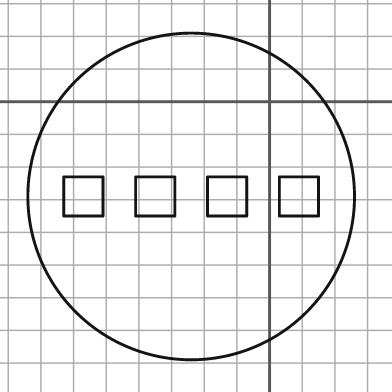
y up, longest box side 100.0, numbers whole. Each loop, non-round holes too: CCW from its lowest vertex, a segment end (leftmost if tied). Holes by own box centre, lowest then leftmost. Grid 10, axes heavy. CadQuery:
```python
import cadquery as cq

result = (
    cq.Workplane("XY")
    .moveTo(-24.0, -29.0)
    .circle(50.0)
    .moveTo(-63.0, -35.0)
    .lineTo(-51.0, -35.0)
    .lineTo(-51.0, -23.0)
    .lineTo(-63.0, -23.0)
    .close()
    .moveTo(-41.0, -35.0)
    .lineTo(-29.0, -35.0)
    .lineTo(-29.0, -23.0)
    .lineTo(-41.0, -23.0)
    .close()
    .moveTo(-19.0, -35.0)
    .lineTo(-7.0, -35.0)
    .lineTo(-7.0, -23.0)
    .lineTo(-19.0, -23.0)
    .close()
    .moveTo(3.0, -35.0)
    .lineTo(15.0, -35.0)
    .lineTo(15.0, -23.0)
    .lineTo(3.0, -23.0)
    .close()
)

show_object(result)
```